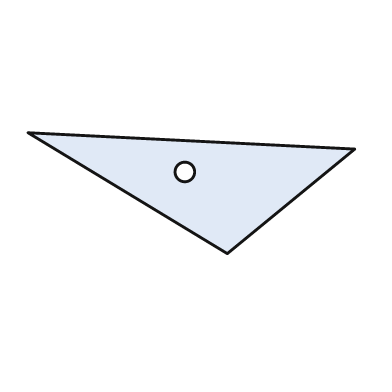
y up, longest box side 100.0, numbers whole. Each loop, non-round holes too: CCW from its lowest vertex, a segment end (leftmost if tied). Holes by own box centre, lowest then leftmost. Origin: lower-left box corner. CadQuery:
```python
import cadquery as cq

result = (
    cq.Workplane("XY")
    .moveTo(61.0, 0.0)
    .lineTo(100.0, 32.0)
    .lineTo(0.0, 37.0)
    .close()
    .moveTo(48.0, 25.0)
    .circle(3.0)
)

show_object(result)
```